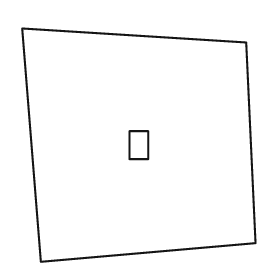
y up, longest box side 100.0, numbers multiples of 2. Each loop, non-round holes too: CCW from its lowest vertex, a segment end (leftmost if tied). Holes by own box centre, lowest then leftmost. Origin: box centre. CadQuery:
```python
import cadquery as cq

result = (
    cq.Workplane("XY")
    .moveTo(-42.0, -50.0)
    .lineTo(50.0, -42.0)
    .lineTo(46.0, 44.0)
    .lineTo(-50.0, 50.0)
    .close()
    .moveTo(-4.0, -6.0)
    .lineTo(4.0, -6.0)
    .lineTo(4.0, 6.0)
    .lineTo(-4.0, 6.0)
    .close()
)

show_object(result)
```